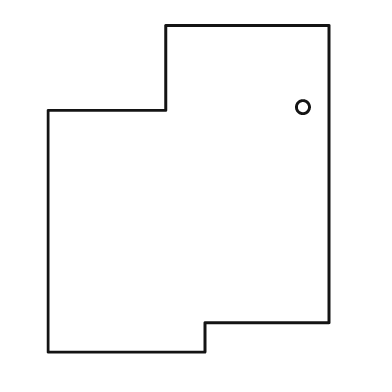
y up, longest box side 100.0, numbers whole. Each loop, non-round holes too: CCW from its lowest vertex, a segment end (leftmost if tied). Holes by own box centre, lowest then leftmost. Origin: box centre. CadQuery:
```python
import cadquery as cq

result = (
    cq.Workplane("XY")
    .moveTo(-43.0, -50.0)
    .lineTo(5.0, -50.0)
    .lineTo(5.0, -41.0)
    .lineTo(43.0, -41.0)
    .lineTo(43.0, 50.0)
    .lineTo(-7.0, 50.0)
    .lineTo(-7.0, 24.0)
    .lineTo(-43.0, 24.0)
    .close()
    .moveTo(35.0, 25.0)
    .circle(2.0)
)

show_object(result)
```